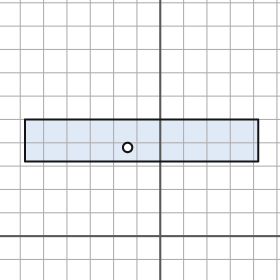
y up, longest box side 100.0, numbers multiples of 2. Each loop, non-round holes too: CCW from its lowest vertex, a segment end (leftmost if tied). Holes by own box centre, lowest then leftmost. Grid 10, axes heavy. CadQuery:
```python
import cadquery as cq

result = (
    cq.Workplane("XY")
    .moveTo(-58.0, 32.0)
    .lineTo(42.0, 32.0)
    .lineTo(42.0, 50.0)
    .lineTo(-58.0, 50.0)
    .close()
    .moveTo(-14.0, 38.0)
    .circle(2.0)
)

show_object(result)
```